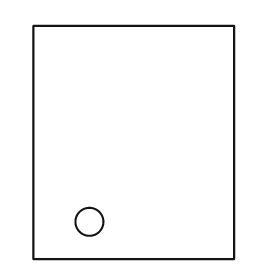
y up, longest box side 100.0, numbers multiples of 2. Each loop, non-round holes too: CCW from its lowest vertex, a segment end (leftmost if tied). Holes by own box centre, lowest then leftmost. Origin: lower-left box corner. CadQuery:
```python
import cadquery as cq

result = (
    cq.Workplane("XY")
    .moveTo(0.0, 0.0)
    .lineTo(86.0, 0.0)
    .lineTo(86.0, 100.0)
    .lineTo(0.0, 100.0)
    .close()
    .moveTo(24.0, 16.0)
    .circle(6.0)
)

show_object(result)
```